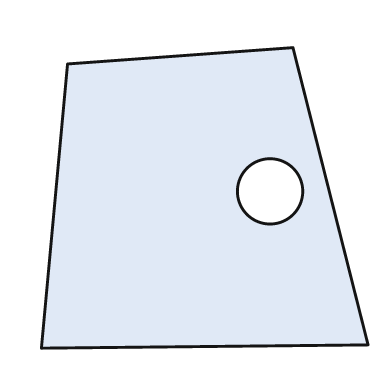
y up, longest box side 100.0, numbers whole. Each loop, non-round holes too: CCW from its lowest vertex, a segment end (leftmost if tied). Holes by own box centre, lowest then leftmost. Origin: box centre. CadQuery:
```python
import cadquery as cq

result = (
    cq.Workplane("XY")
    .moveTo(-50.0, -46.0)
    .lineTo(50.0, -45.0)
    .lineTo(27.0, 46.0)
    .lineTo(-42.0, 41.0)
    .close()
    .moveTo(20.0, 2.0)
    .circle(10.0)
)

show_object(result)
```